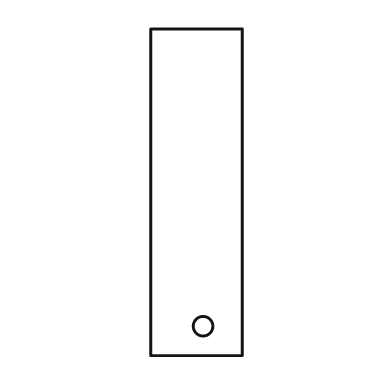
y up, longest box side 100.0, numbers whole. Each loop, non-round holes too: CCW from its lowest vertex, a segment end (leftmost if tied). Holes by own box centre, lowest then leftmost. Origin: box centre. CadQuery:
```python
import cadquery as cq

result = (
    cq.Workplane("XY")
    .moveTo(-14.0, -50.0)
    .lineTo(14.0, -50.0)
    .lineTo(14.0, 50.0)
    .lineTo(-14.0, 50.0)
    .close()
    .moveTo(2.0, -41.0)
    .circle(3.0)
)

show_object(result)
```